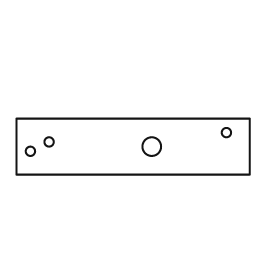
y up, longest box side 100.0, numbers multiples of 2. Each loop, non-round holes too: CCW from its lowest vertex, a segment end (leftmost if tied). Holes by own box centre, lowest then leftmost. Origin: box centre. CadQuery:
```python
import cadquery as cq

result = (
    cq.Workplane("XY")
    .moveTo(-50.0, -12.0)
    .lineTo(50.0, -12.0)
    .lineTo(50.0, 12.0)
    .lineTo(-50.0, 12.0)
    .close()
    .moveTo(-44.0, -2.0)
    .circle(2.0)
    .moveTo(8.0, 0.0)
    .circle(4.0)
    .moveTo(-36.0, 2.0)
    .circle(2.0)
    .moveTo(40.0, 6.0)
    .circle(2.0)
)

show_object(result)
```